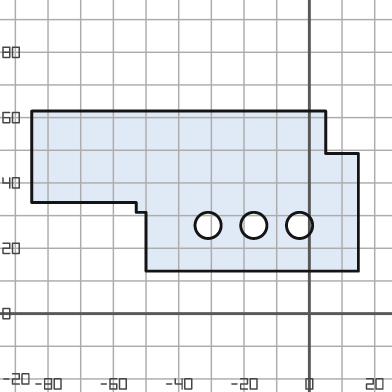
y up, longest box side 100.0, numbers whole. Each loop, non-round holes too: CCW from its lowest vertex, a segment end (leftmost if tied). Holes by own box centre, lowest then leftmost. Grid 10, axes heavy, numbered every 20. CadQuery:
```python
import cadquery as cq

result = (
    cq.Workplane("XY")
    .moveTo(-50.0, 13.0)
    .lineTo(15.0, 13.0)
    .lineTo(15.0, 49.0)
    .lineTo(5.0, 49.0)
    .lineTo(5.0, 62.0)
    .lineTo(-85.0, 62.0)
    .lineTo(-85.0, 34.0)
    .lineTo(-53.0, 34.0)
    .lineTo(-53.0, 31.0)
    .lineTo(-50.0, 31.0)
    .close()
    .moveTo(-31.0, 27.0)
    .circle(4.0)
    .moveTo(-17.0, 27.0)
    .circle(4.0)
    .moveTo(-3.0, 27.0)
    .circle(4.0)
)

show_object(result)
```